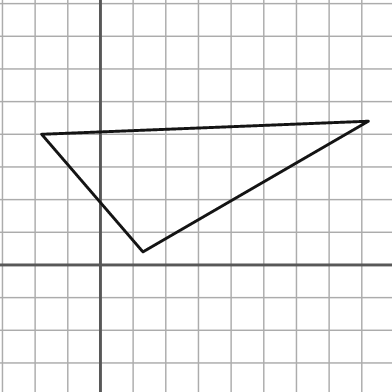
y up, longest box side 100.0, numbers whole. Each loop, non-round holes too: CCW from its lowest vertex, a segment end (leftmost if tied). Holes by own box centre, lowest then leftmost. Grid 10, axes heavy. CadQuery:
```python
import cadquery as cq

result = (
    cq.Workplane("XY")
    .moveTo(13.0, 4.0)
    .lineTo(82.0, 44.0)
    .lineTo(-18.0, 40.0)
    .close()
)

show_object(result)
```